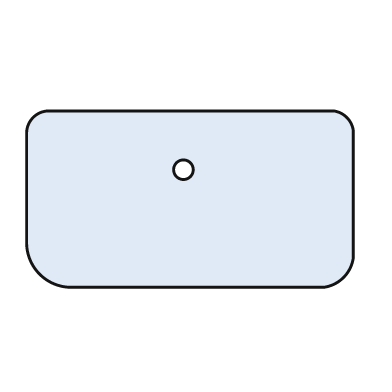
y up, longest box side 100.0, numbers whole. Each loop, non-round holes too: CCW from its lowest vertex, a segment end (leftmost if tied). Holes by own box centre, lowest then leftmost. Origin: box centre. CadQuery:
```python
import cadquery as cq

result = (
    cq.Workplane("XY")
    .moveTo(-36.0, -27.0)
    .lineTo(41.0, -27.0)
    .threePointArc((47.0, -24.0), (50.0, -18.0))
    .lineTo(50.0, 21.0)
    .threePointArc((48.0, 25.0), (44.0, 27.0))
    .lineTo(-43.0, 27.0)
    .threePointArc((-48.0, 25.0), (-50.0, 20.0))
    .lineTo(-50.0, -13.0)
    .threePointArc((-46.0, -23.0), (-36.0, -27.0))
    .close()
    .moveTo(-2.0, 9.0)
    .circle(3.0)
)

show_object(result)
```